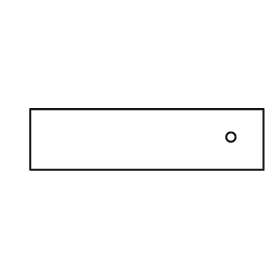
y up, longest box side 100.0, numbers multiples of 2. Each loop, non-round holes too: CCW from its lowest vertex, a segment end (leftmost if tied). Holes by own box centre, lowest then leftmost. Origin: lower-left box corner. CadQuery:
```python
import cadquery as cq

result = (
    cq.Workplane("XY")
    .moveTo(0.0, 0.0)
    .lineTo(100.0, 0.0)
    .lineTo(100.0, 26.0)
    .lineTo(0.0, 26.0)
    .close()
    .moveTo(86.0, 14.0)
    .circle(2.0)
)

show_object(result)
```